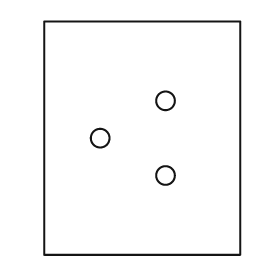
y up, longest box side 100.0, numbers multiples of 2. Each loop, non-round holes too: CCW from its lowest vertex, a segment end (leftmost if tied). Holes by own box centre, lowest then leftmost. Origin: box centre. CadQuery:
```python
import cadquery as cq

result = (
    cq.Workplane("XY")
    .moveTo(-42.0, -50.0)
    .lineTo(42.0, -50.0)
    .lineTo(42.0, 50.0)
    .lineTo(-42.0, 50.0)
    .close()
    .moveTo(10.0, -16.0)
    .circle(4.0)
    .moveTo(-18.0, 0.0)
    .circle(4.0)
    .moveTo(10.0, 16.0)
    .circle(4.0)
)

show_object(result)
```